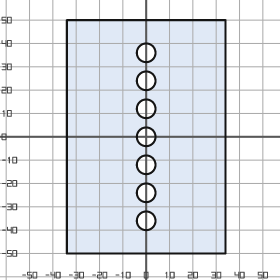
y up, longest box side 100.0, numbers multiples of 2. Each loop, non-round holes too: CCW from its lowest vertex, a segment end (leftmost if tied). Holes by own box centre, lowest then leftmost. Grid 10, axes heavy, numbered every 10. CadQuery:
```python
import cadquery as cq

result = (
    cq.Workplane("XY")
    .moveTo(-34.0, -50.0)
    .lineTo(34.0, -50.0)
    .lineTo(34.0, 50.0)
    .lineTo(-34.0, 50.0)
    .close()
    .moveTo(0.0, -36.0)
    .circle(4.0)
    .moveTo(0.0, -24.0)
    .circle(4.0)
    .moveTo(0.0, -12.0)
    .circle(4.0)
    .moveTo(0.0, 0.0)
    .circle(4.0)
    .moveTo(0.0, 12.0)
    .circle(4.0)
    .moveTo(0.0, 24.0)
    .circle(4.0)
    .moveTo(0.0, 36.0)
    .circle(4.0)
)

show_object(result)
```